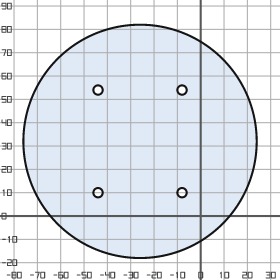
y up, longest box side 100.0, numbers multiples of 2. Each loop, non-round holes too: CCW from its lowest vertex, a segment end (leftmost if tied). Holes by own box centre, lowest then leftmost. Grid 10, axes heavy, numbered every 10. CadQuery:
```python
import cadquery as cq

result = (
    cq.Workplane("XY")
    .moveTo(-26.0, 32.0)
    .circle(50.0)
    .moveTo(-44.0, 10.0)
    .circle(2.0)
    .moveTo(-8.0, 10.0)
    .circle(2.0)
    .moveTo(-44.0, 54.0)
    .circle(2.0)
    .moveTo(-8.0, 54.0)
    .circle(2.0)
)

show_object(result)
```